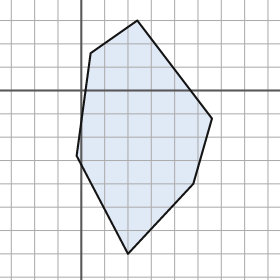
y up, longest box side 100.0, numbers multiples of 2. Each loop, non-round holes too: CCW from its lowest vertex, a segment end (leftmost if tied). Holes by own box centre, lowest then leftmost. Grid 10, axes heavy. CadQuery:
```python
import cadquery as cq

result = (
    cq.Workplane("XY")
    .moveTo(20.0, -70.0)
    .lineTo(48.0, -40.0)
    .lineTo(56.0, -12.0)
    .lineTo(24.0, 30.0)
    .lineTo(4.0, 16.0)
    .lineTo(-2.0, -28.0)
    .close()
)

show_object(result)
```